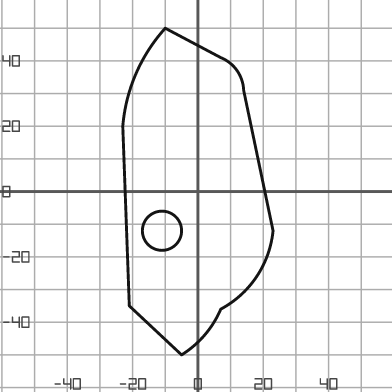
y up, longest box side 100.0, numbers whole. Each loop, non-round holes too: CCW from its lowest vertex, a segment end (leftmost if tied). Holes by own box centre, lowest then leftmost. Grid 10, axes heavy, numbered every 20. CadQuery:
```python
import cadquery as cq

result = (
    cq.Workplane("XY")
    .moveTo(-5.0, -50.0)
    .threePointArc((2.0, -44.0), (7.0, -36.0))
    .threePointArc((18.0, -26.0), (23.0, -12.0))
    .lineTo(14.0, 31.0)
    .threePointArc((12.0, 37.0), (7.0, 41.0))
    .lineTo(-10.0, 50.0)
    .threePointArc((-19.0, 36.0), (-23.0, 20.0))
    .lineTo(-21.0, -35.0)
    .close()
    .moveTo(-11.0, -12.0)
    .circle(6.0)
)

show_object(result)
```